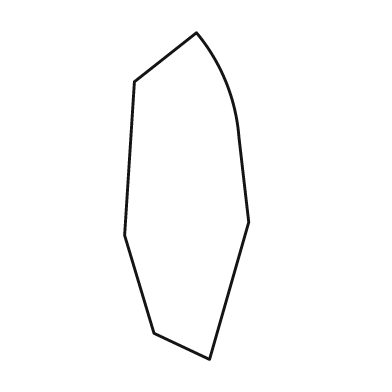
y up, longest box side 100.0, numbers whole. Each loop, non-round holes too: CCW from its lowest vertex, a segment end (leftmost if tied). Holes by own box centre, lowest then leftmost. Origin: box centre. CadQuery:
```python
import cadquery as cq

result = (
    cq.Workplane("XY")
    .moveTo(7.0, -50.0)
    .lineTo(19.0, -8.0)
    .lineTo(16.0, 18.0)
    .threePointArc((12.0, 35.0), (3.0, 50.0))
    .lineTo(-16.0, 35.0)
    .lineTo(-19.0, -12.0)
    .lineTo(-10.0, -42.0)
    .close()
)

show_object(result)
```